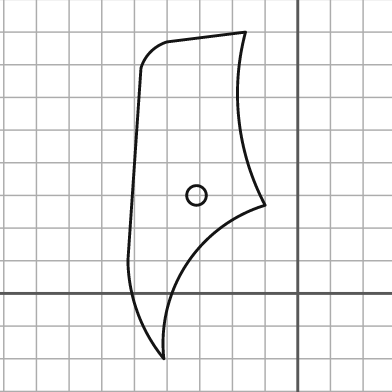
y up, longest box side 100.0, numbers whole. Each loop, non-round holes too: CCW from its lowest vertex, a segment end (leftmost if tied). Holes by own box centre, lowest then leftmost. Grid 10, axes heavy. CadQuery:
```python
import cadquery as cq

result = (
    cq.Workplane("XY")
    .moveTo(-41.0, -20.0)
    .threePointArc((-34.0, 9.0), (-10.0, 27.0))
    .threePointArc((-18.0, 53.0), (-16.0, 80.0))
    .lineTo(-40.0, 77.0)
    .threePointArc((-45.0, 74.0), (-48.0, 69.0))
    .lineTo(-52.0, 10.0)
    .threePointArc((-49.0, -6.0), (-41.0, -20.0))
    .close()
    .moveTo(-31.0, 30.0)
    .circle(3.0)
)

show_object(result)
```